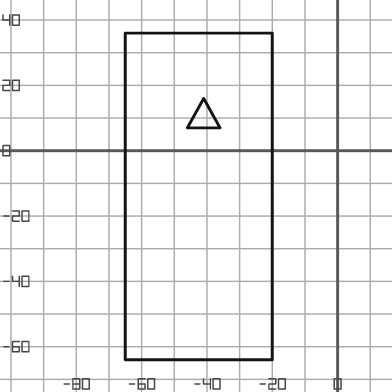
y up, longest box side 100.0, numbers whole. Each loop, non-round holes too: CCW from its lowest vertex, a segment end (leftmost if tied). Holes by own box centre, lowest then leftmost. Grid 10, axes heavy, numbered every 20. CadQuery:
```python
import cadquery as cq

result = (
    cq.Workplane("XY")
    .moveTo(-65.0, -64.0)
    .lineTo(-20.0, -64.0)
    .lineTo(-20.0, 36.0)
    .lineTo(-65.0, 36.0)
    .close()
    .moveTo(-46.0, 7.0)
    .lineTo(-36.0, 7.0)
    .lineTo(-41.0, 16.0)
    .close()
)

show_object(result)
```